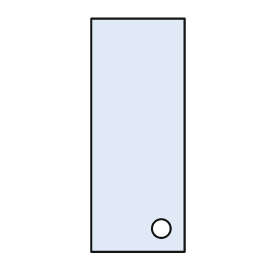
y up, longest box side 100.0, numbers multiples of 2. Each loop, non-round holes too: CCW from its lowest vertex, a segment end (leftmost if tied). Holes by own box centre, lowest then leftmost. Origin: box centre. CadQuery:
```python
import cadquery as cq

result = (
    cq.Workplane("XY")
    .moveTo(-20.0, -50.0)
    .lineTo(20.0, -50.0)
    .lineTo(20.0, 50.0)
    .lineTo(-20.0, 50.0)
    .close()
    .moveTo(10.0, -40.0)
    .circle(4.0)
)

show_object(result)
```